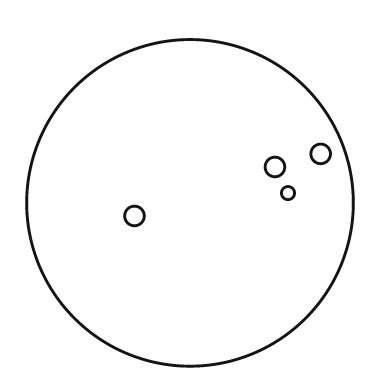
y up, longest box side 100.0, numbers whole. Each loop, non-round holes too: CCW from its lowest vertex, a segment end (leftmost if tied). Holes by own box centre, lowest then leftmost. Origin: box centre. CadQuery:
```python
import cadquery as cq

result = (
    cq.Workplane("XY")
    .moveTo(0.0, 0.0)
    .circle(50.0)
    .moveTo(-17.0, -4.0)
    .circle(3.0)
    .moveTo(30.0, 3.0)
    .circle(2.0)
    .moveTo(26.0, 11.0)
    .circle(3.0)
    .moveTo(40.0, 15.0)
    .circle(3.0)
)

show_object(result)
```